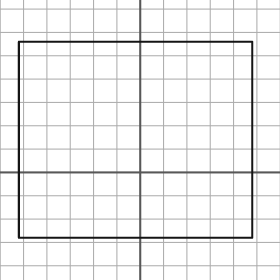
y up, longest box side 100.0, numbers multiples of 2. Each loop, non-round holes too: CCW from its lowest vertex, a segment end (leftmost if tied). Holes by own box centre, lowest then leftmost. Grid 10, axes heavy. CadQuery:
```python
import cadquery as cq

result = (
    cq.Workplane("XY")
    .moveTo(-52.0, -28.0)
    .lineTo(48.0, -28.0)
    .lineTo(48.0, 56.0)
    .lineTo(-52.0, 56.0)
    .close()
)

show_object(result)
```